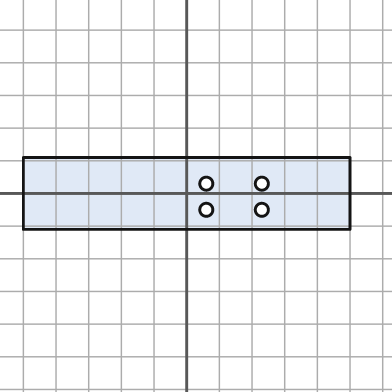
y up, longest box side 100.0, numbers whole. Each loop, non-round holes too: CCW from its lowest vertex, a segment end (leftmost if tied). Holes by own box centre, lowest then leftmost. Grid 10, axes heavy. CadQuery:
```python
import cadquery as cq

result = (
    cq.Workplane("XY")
    .moveTo(-50.0, -11.0)
    .lineTo(50.0, -11.0)
    .lineTo(50.0, 11.0)
    .lineTo(-50.0, 11.0)
    .close()
    .moveTo(6.0, -5.0)
    .circle(2.0)
    .moveTo(23.0, -5.0)
    .circle(2.0)
    .moveTo(6.0, 3.0)
    .circle(2.0)
    .moveTo(23.0, 3.0)
    .circle(2.0)
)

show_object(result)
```